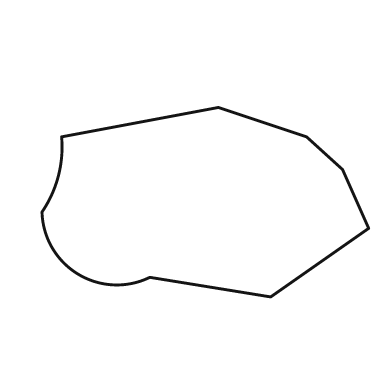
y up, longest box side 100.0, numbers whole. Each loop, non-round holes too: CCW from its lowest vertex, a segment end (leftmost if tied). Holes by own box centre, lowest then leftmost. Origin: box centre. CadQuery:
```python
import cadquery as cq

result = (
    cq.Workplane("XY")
    .moveTo(20.0, -29.0)
    .lineTo(50.0, -8.0)
    .lineTo(42.0, 10.0)
    .lineTo(31.0, 20.0)
    .lineTo(4.0, 29.0)
    .lineTo(-44.0, 20.0)
    .threePointArc((-45.0, 8.0), (-50.0, -3.0))
    .threePointArc((-39.0, -22.0), (-17.0, -23.0))
    .close()
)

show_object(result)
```